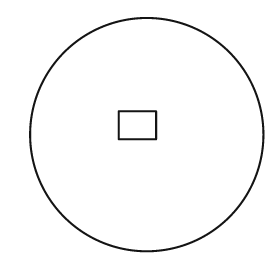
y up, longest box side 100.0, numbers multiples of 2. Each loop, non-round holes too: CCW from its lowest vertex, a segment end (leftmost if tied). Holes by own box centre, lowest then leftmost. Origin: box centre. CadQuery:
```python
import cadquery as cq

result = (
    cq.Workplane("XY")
    .moveTo(0.0, 0.0)
    .circle(50.0)
    .moveTo(-12.0, -2.0)
    .lineTo(4.0, -2.0)
    .lineTo(4.0, 10.0)
    .lineTo(-12.0, 10.0)
    .close()
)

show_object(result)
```